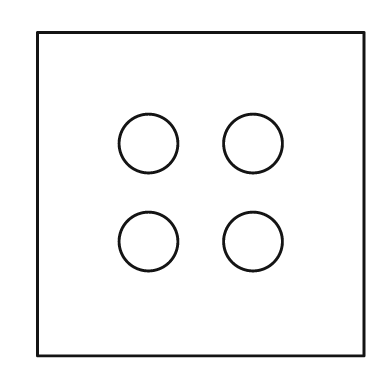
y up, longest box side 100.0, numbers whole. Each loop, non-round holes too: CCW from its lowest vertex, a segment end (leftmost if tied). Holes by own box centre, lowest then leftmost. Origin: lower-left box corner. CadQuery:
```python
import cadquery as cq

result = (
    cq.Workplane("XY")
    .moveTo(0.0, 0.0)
    .lineTo(100.0, 0.0)
    .lineTo(100.0, 99.0)
    .lineTo(0.0, 99.0)
    .close()
    .moveTo(34.0, 35.0)
    .circle(9.0)
    .moveTo(66.0, 35.0)
    .circle(9.0)
    .moveTo(34.0, 65.0)
    .circle(9.0)
    .moveTo(66.0, 65.0)
    .circle(9.0)
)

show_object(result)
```